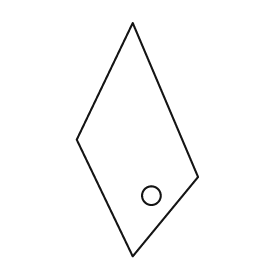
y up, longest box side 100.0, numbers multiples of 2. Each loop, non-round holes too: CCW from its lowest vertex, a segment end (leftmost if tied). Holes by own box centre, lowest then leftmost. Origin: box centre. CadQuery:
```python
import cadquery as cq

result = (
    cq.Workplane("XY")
    .moveTo(-2.0, -50.0)
    .lineTo(26.0, -16.0)
    .lineTo(-2.0, 50.0)
    .lineTo(-26.0, 0.0)
    .close()
    .moveTo(6.0, -24.0)
    .circle(4.0)
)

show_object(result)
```